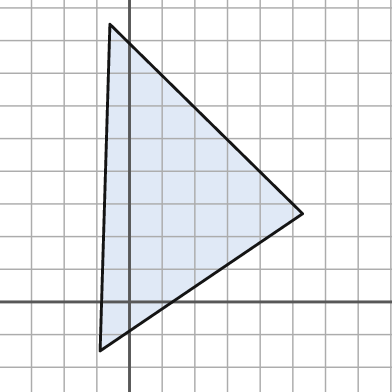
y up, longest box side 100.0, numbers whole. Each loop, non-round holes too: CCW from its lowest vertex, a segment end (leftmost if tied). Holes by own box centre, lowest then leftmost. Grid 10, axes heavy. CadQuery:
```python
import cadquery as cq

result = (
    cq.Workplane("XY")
    .moveTo(-9.0, -15.0)
    .lineTo(53.0, 27.0)
    .lineTo(-6.0, 85.0)
    .close()
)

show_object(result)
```